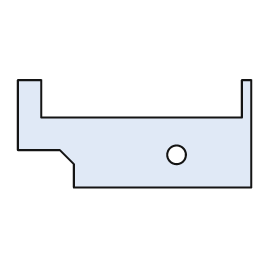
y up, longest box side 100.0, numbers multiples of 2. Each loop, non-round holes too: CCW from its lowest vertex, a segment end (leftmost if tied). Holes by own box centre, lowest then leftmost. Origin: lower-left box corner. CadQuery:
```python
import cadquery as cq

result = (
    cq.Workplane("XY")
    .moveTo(24.0, 0.0)
    .lineTo(100.0, 0.0)
    .lineTo(100.0, 46.0)
    .lineTo(96.0, 46.0)
    .lineTo(96.0, 30.0)
    .lineTo(10.0, 30.0)
    .lineTo(10.0, 46.0)
    .lineTo(0.0, 46.0)
    .lineTo(0.0, 16.0)
    .lineTo(18.0, 16.0)
    .lineTo(24.0, 10.0)
    .close()
    .moveTo(68.0, 14.0)
    .circle(4.0)
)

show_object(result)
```